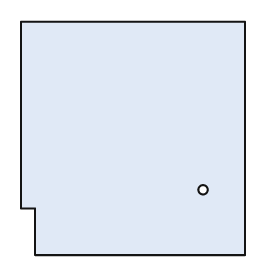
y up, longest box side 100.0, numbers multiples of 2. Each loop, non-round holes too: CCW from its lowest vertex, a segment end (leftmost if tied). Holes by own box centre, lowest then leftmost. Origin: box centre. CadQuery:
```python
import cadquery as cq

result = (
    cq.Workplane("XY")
    .moveTo(-42.0, -50.0)
    .lineTo(48.0, -50.0)
    .lineTo(48.0, 50.0)
    .lineTo(-48.0, 50.0)
    .lineTo(-48.0, -30.0)
    .lineTo(-42.0, -30.0)
    .close()
    .moveTo(30.0, -22.0)
    .circle(2.0)
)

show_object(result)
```